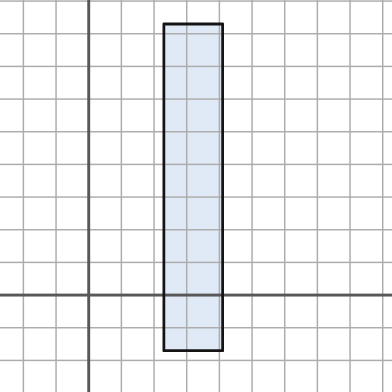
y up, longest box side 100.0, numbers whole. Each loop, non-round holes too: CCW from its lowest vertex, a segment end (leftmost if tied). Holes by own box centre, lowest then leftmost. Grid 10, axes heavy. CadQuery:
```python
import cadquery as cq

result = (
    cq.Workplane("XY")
    .moveTo(23.0, -17.0)
    .lineTo(41.0, -17.0)
    .lineTo(41.0, 83.0)
    .lineTo(23.0, 83.0)
    .close()
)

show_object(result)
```